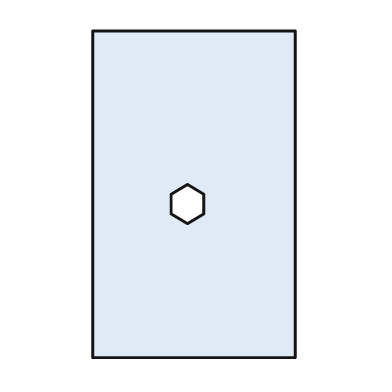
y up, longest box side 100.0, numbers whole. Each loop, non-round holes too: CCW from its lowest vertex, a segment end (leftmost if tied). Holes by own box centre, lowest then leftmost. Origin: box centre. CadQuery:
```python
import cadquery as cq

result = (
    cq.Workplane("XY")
    .moveTo(-31.0, -50.0)
    .lineTo(31.0, -50.0)
    .lineTo(31.0, 50.0)
    .lineTo(-31.0, 50.0)
    .close()
    .moveTo(-2.0, -9.0)
    .lineTo(3.0, -6.0)
    .lineTo(3.0, 0.0)
    .lineTo(-2.0, 3.0)
    .lineTo(-7.0, 0.0)
    .lineTo(-7.0, -6.0)
    .close()
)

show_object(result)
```